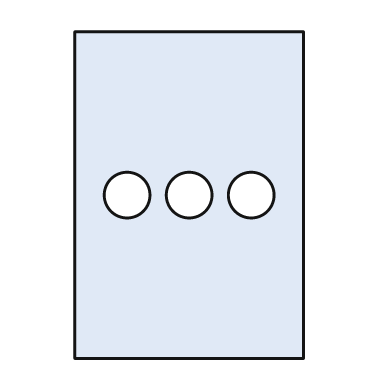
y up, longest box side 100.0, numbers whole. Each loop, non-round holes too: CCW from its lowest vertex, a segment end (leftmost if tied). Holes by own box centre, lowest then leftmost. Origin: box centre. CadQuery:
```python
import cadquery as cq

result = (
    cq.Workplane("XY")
    .moveTo(-35.0, -50.0)
    .lineTo(35.0, -50.0)
    .lineTo(35.0, 50.0)
    .lineTo(-35.0, 50.0)
    .close()
    .moveTo(-19.0, 0.0)
    .circle(7.0)
    .moveTo(0.0, 0.0)
    .circle(7.0)
    .moveTo(19.0, 0.0)
    .circle(7.0)
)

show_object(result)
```